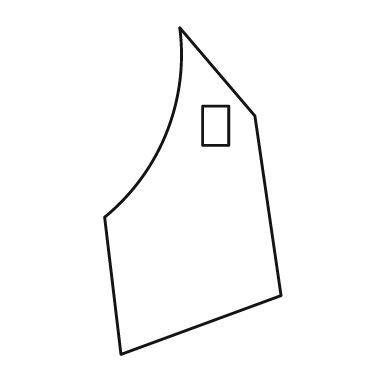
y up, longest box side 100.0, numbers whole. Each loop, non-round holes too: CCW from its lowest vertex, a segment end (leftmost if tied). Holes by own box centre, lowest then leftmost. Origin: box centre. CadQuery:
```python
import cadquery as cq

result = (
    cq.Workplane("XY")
    .moveTo(-22.0, -50.0)
    .lineTo(27.0, -32.0)
    .lineTo(19.0, 23.0)
    .lineTo(-4.0, 50.0)
    .threePointArc((-8.0, 18.0), (-27.0, -8.0))
    .close()
    .moveTo(3.0, 14.0)
    .lineTo(11.0, 14.0)
    .lineTo(11.0, 26.0)
    .lineTo(3.0, 26.0)
    .close()
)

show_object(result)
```